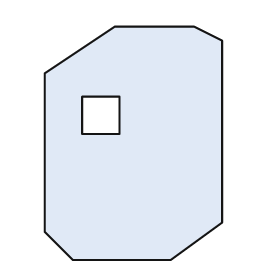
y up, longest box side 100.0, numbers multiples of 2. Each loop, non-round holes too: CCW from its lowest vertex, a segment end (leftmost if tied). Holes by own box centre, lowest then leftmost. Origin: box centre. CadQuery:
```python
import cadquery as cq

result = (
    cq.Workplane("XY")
    .moveTo(-26.0, -50.0)
    .lineTo(16.0, -50.0)
    .lineTo(38.0, -34.0)
    .lineTo(38.0, 44.0)
    .lineTo(26.0, 50.0)
    .lineTo(-8.0, 50.0)
    .lineTo(-38.0, 30.0)
    .lineTo(-38.0, -38.0)
    .close()
    .moveTo(-22.0, 4.0)
    .lineTo(-6.0, 4.0)
    .lineTo(-6.0, 20.0)
    .lineTo(-22.0, 20.0)
    .close()
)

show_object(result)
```